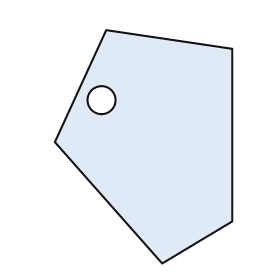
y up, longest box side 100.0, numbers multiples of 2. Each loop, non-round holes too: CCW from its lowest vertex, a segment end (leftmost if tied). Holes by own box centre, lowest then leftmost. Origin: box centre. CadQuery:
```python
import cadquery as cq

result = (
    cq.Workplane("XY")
    .moveTo(8.0, -50.0)
    .lineTo(38.0, -32.0)
    .lineTo(38.0, 42.0)
    .lineTo(-16.0, 50.0)
    .lineTo(-38.0, 2.0)
    .close()
    .moveTo(-18.0, 20.0)
    .circle(6.0)
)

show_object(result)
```